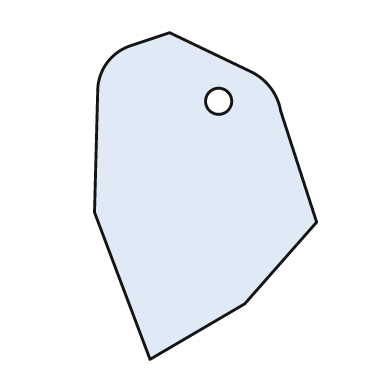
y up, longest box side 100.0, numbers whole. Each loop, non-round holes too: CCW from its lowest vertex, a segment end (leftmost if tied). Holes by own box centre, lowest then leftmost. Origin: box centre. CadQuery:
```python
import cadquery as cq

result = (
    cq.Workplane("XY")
    .moveTo(-17.0, -50.0)
    .lineTo(12.0, -33.0)
    .lineTo(34.0, -8.0)
    .lineTo(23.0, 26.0)
    .threePointArc((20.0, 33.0), (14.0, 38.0))
    .lineTo(-11.0, 50.0)
    .lineTo(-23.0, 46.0)
    .threePointArc((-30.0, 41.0), (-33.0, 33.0))
    .lineTo(-34.0, -5.0)
    .close()
    .moveTo(4.0, 29.0)
    .circle(4.0)
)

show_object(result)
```